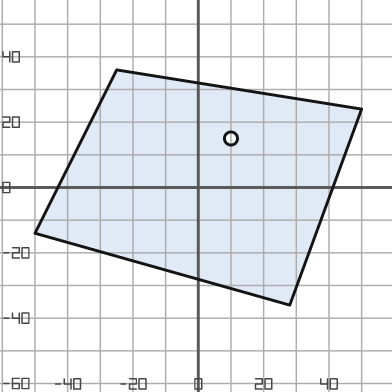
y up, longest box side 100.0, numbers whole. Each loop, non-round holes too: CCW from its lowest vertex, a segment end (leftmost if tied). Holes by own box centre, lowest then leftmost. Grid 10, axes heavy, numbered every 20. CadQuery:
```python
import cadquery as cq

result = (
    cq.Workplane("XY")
    .moveTo(28.0, -36.0)
    .lineTo(50.0, 24.0)
    .lineTo(-25.0, 36.0)
    .lineTo(-50.0, -14.0)
    .close()
    .moveTo(10.0, 15.0)
    .circle(2.0)
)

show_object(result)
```